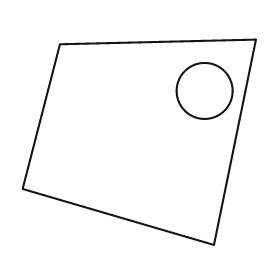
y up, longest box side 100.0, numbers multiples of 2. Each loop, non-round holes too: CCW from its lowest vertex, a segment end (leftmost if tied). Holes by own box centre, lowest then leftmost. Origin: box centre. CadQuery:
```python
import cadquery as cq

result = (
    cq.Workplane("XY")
    .moveTo(32.0, -44.0)
    .lineTo(50.0, 44.0)
    .lineTo(-34.0, 42.0)
    .lineTo(-50.0, -20.0)
    .close()
    .moveTo(28.0, 22.0)
    .circle(12.0)
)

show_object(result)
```